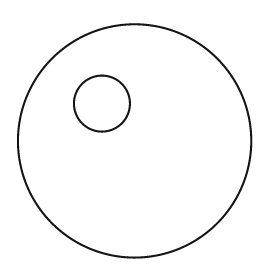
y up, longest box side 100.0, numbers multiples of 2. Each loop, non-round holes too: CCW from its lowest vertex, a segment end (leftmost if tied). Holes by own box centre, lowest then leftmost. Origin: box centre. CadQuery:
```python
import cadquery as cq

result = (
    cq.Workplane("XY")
    .moveTo(0.0, 0.0)
    .circle(50.0)
    .moveTo(-14.0, 16.0)
    .circle(12.0)
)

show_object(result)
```